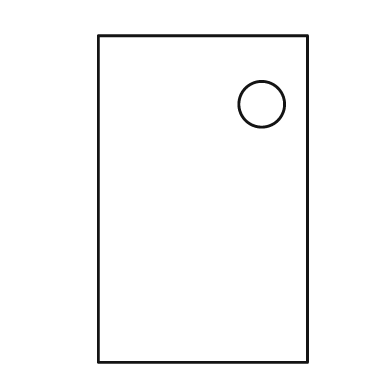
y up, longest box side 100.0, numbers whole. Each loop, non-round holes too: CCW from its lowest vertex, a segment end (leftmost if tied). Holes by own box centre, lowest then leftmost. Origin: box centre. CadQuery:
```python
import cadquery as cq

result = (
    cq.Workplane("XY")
    .moveTo(-32.0, -50.0)
    .lineTo(32.0, -50.0)
    .lineTo(32.0, 50.0)
    .lineTo(-32.0, 50.0)
    .close()
    .moveTo(18.0, 29.0)
    .circle(7.0)
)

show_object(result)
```